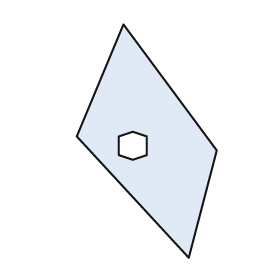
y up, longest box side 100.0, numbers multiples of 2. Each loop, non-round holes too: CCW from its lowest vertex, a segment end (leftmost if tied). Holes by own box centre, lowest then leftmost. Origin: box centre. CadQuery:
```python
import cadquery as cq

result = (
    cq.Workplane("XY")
    .moveTo(18.0, -50.0)
    .lineTo(30.0, -4.0)
    .lineTo(-10.0, 50.0)
    .lineTo(-30.0, 2.0)
    .close()
    .moveTo(-6.0, -8.0)
    .lineTo(0.0, -6.0)
    .lineTo(0.0, 2.0)
    .lineTo(-6.0, 4.0)
    .lineTo(-12.0, 2.0)
    .lineTo(-12.0, -6.0)
    .close()
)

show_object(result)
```